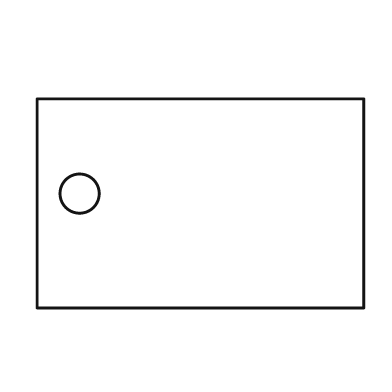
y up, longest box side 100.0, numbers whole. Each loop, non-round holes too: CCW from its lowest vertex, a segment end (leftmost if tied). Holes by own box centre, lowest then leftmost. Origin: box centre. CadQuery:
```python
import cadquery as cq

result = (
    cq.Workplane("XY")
    .moveTo(-50.0, -32.0)
    .lineTo(50.0, -32.0)
    .lineTo(50.0, 32.0)
    .lineTo(-50.0, 32.0)
    .close()
    .moveTo(-37.0, 3.0)
    .circle(6.0)
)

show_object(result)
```